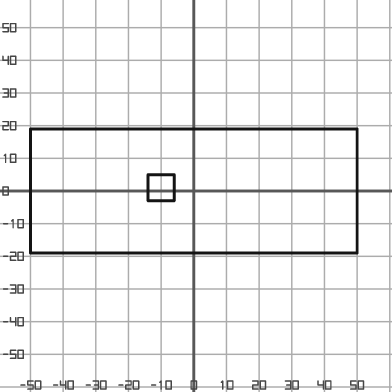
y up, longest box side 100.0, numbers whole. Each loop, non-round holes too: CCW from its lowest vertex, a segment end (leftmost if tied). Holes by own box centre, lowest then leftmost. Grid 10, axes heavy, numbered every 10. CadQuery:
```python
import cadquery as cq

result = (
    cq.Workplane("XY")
    .moveTo(-50.0, -19.0)
    .lineTo(50.0, -19.0)
    .lineTo(50.0, 19.0)
    .lineTo(-50.0, 19.0)
    .close()
    .moveTo(-14.0, -3.0)
    .lineTo(-6.0, -3.0)
    .lineTo(-6.0, 5.0)
    .lineTo(-14.0, 5.0)
    .close()
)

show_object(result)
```